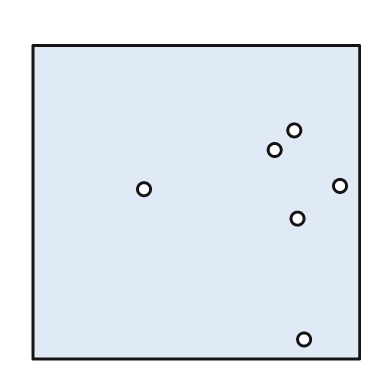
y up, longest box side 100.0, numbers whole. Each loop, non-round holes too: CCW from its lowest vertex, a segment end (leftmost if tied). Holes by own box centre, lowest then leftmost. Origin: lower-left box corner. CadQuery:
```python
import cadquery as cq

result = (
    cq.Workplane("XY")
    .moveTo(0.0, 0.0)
    .lineTo(100.0, 0.0)
    .lineTo(100.0, 96.0)
    .lineTo(0.0, 96.0)
    .close()
    .moveTo(83.0, 6.0)
    .circle(2.0)
    .moveTo(81.0, 43.0)
    .circle(2.0)
    .moveTo(34.0, 52.0)
    .circle(2.0)
    .moveTo(94.0, 53.0)
    .circle(2.0)
    .moveTo(74.0, 64.0)
    .circle(2.0)
    .moveTo(80.0, 70.0)
    .circle(2.0)
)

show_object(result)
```